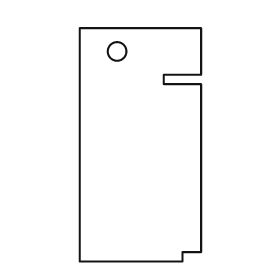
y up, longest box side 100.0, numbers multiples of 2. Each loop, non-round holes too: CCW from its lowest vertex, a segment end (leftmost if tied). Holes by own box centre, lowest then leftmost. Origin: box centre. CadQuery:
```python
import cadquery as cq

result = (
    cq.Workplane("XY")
    .moveTo(-26.0, -50.0)
    .lineTo(18.0, -50.0)
    .lineTo(18.0, -46.0)
    .lineTo(26.0, -46.0)
    .lineTo(26.0, 26.0)
    .lineTo(10.0, 26.0)
    .lineTo(10.0, 30.0)
    .lineTo(26.0, 30.0)
    .lineTo(26.0, 50.0)
    .lineTo(-26.0, 50.0)
    .close()
    .moveTo(-10.0, 40.0)
    .circle(4.0)
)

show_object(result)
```